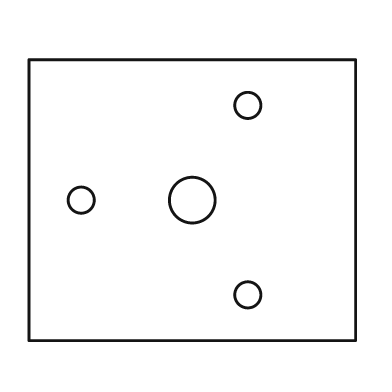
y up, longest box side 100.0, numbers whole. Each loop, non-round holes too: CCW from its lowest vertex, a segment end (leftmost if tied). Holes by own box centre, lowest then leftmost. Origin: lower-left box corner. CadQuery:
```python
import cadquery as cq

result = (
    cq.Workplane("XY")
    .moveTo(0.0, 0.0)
    .lineTo(100.0, 0.0)
    .lineTo(100.0, 86.0)
    .lineTo(0.0, 86.0)
    .close()
    .moveTo(67.0, 14.0)
    .circle(4.0)
    .moveTo(16.0, 43.0)
    .circle(4.0)
    .moveTo(50.0, 43.0)
    .circle(7.0)
    .moveTo(67.0, 72.0)
    .circle(4.0)
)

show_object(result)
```